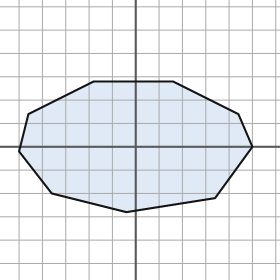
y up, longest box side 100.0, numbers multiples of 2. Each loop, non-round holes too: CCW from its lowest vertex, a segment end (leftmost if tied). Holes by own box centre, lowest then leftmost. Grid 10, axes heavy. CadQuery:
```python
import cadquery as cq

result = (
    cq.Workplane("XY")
    .moveTo(-4.0, -28.0)
    .lineTo(34.0, -22.0)
    .lineTo(50.0, 0.0)
    .lineTo(44.0, 14.0)
    .lineTo(16.0, 28.0)
    .lineTo(-18.0, 28.0)
    .lineTo(-46.0, 14.0)
    .lineTo(-50.0, -2.0)
    .lineTo(-36.0, -20.0)
    .close()
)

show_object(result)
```